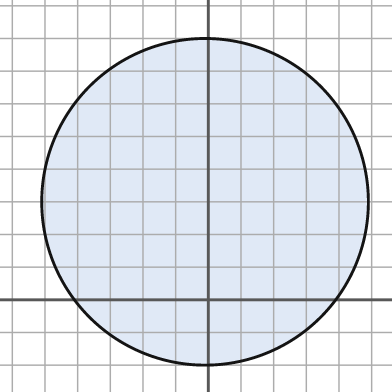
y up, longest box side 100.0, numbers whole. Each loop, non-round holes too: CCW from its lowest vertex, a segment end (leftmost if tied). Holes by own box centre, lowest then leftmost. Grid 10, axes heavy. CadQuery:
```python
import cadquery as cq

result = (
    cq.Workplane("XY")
    .moveTo(-1.0, 30.0)
    .circle(50.0)
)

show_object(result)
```